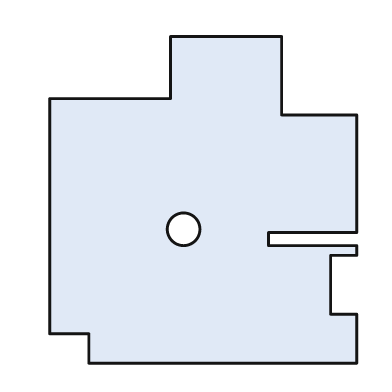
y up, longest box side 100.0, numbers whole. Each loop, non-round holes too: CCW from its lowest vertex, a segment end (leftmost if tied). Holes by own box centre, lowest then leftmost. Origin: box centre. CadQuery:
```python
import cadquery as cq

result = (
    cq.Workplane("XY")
    .moveTo(-35.0, -50.0)
    .lineTo(47.0, -50.0)
    .lineTo(47.0, -35.0)
    .lineTo(39.0, -35.0)
    .lineTo(39.0, -17.0)
    .lineTo(47.0, -17.0)
    .lineTo(47.0, -14.0)
    .lineTo(20.0, -14.0)
    .lineTo(20.0, -10.0)
    .lineTo(47.0, -10.0)
    .lineTo(47.0, 26.0)
    .lineTo(24.0, 26.0)
    .lineTo(24.0, 50.0)
    .lineTo(-10.0, 50.0)
    .lineTo(-10.0, 31.0)
    .lineTo(-47.0, 31.0)
    .lineTo(-47.0, -41.0)
    .lineTo(-35.0, -41.0)
    .close()
    .moveTo(-6.0, -9.0)
    .circle(5.0)
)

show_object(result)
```